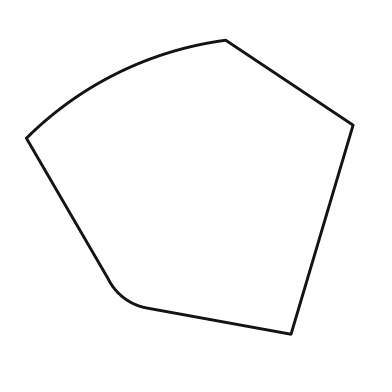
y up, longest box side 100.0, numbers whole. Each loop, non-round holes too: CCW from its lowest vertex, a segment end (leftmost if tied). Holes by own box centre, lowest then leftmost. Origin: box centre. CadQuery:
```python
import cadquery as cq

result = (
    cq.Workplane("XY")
    .moveTo(31.0, -45.0)
    .lineTo(50.0, 19.0)
    .lineTo(11.0, 45.0)
    .threePointArc((-22.0, 35.0), (-50.0, 15.0))
    .lineTo(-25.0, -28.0)
    .threePointArc((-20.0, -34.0), (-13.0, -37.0))
    .close()
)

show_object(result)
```